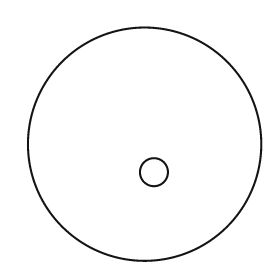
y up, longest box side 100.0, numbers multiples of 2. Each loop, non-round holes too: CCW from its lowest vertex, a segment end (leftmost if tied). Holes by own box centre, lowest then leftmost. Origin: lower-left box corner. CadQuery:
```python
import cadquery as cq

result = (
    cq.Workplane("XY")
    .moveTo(50.0, 50.0)
    .circle(50.0)
    .moveTo(54.0, 38.0)
    .circle(6.0)
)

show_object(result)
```